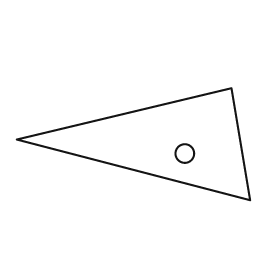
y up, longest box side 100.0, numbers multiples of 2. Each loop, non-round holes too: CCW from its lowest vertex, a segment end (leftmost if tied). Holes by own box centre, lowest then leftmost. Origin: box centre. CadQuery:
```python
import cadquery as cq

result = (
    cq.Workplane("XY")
    .moveTo(50.0, -24.0)
    .lineTo(42.0, 24.0)
    .lineTo(-50.0, 2.0)
    .close()
    .moveTo(22.0, -4.0)
    .circle(4.0)
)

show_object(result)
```